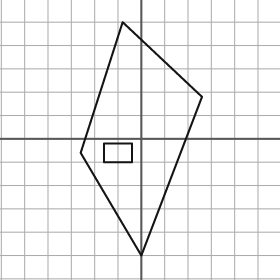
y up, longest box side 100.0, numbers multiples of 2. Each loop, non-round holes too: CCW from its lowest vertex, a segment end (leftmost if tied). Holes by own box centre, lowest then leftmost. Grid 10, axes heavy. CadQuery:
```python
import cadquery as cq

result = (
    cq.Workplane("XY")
    .moveTo(0.0, -50.0)
    .lineTo(26.0, 18.0)
    .lineTo(-8.0, 50.0)
    .lineTo(-26.0, -6.0)
    .close()
    .moveTo(-16.0, -10.0)
    .lineTo(-4.0, -10.0)
    .lineTo(-4.0, -2.0)
    .lineTo(-16.0, -2.0)
    .close()
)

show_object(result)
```